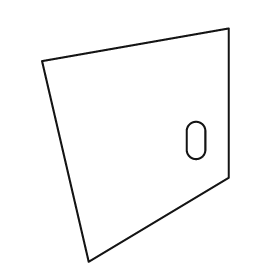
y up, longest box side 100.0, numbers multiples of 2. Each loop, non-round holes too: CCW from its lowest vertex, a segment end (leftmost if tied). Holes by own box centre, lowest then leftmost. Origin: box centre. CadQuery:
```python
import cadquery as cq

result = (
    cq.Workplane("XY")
    .moveTo(-20.0, -50.0)
    .lineTo(40.0, -14.0)
    .lineTo(40.0, 50.0)
    .lineTo(-40.0, 36.0)
    .close()
    .moveTo(22.0, -2.0)
    .threePointArc((26.0, -6.0), (30.0, -2.0))
    .lineTo(30.0, 6.0)
    .threePointArc((26.0, 10.0), (22.0, 6.0))
    .close()
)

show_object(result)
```